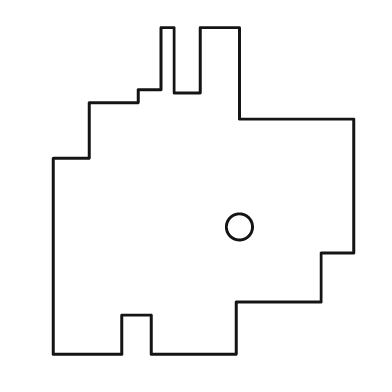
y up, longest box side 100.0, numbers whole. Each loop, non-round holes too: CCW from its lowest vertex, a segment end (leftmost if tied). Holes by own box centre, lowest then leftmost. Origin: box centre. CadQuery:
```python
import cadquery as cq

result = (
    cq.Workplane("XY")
    .moveTo(-46.0, -50.0)
    .lineTo(-25.0, -50.0)
    .lineTo(-25.0, -38.0)
    .lineTo(-16.0, -38.0)
    .lineTo(-16.0, -50.0)
    .lineTo(10.0, -50.0)
    .lineTo(10.0, -34.0)
    .lineTo(36.0, -34.0)
    .lineTo(36.0, -19.0)
    .lineTo(46.0, -19.0)
    .lineTo(46.0, 22.0)
    .lineTo(11.0, 22.0)
    .lineTo(11.0, 50.0)
    .lineTo(-1.0, 50.0)
    .lineTo(-1.0, 30.0)
    .lineTo(-9.0, 30.0)
    .lineTo(-9.0, 50.0)
    .lineTo(-13.0, 50.0)
    .lineTo(-13.0, 31.0)
    .lineTo(-20.0, 31.0)
    .lineTo(-20.0, 27.0)
    .lineTo(-35.0, 27.0)
    .lineTo(-35.0, 10.0)
    .lineTo(-46.0, 10.0)
    .close()
    .moveTo(11.0, -11.0)
    .circle(4.0)
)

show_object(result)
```